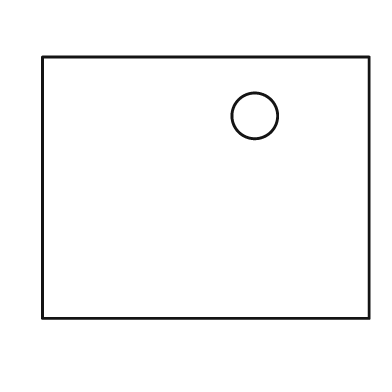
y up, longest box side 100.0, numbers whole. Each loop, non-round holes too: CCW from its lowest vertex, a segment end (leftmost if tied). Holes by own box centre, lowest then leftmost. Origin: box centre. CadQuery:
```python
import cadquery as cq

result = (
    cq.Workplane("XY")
    .moveTo(-50.0, -40.0)
    .lineTo(50.0, -40.0)
    .lineTo(50.0, 40.0)
    .lineTo(-50.0, 40.0)
    .close()
    .moveTo(15.0, 22.0)
    .circle(7.0)
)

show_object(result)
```